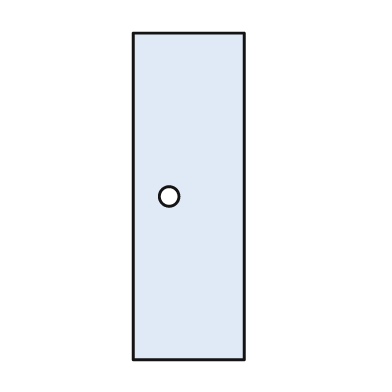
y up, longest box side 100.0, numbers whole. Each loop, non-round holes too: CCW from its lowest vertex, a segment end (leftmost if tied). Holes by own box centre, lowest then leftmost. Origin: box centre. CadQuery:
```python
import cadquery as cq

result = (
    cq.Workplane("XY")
    .moveTo(-17.0, -50.0)
    .lineTo(17.0, -50.0)
    .lineTo(17.0, 50.0)
    .lineTo(-17.0, 50.0)
    .close()
    .moveTo(-6.0, 0.0)
    .circle(3.0)
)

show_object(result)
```